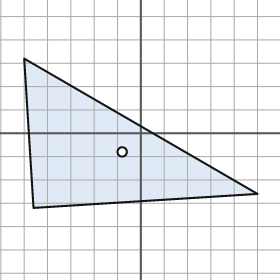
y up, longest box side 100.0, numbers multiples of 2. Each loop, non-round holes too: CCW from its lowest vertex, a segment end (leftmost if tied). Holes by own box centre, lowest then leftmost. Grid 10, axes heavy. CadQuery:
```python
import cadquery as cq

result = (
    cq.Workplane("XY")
    .moveTo(-46.0, -32.0)
    .lineTo(50.0, -26.0)
    .lineTo(-50.0, 32.0)
    .close()
    .moveTo(-8.0, -8.0)
    .circle(2.0)
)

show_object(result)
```